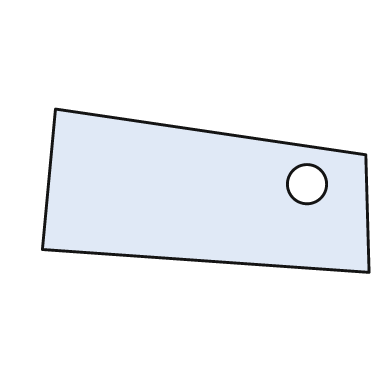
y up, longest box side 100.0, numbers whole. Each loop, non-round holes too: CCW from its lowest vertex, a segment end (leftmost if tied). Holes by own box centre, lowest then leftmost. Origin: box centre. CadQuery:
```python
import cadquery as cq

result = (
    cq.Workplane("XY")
    .moveTo(50.0, -25.0)
    .lineTo(49.0, 11.0)
    .lineTo(-46.0, 25.0)
    .lineTo(-50.0, -18.0)
    .close()
    .moveTo(31.0, 2.0)
    .circle(6.0)
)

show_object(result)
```